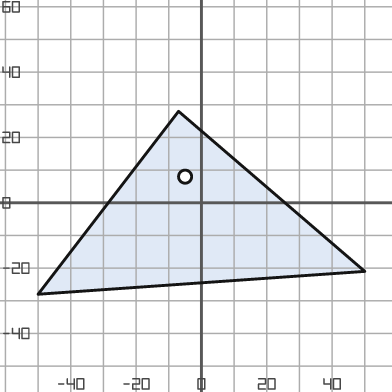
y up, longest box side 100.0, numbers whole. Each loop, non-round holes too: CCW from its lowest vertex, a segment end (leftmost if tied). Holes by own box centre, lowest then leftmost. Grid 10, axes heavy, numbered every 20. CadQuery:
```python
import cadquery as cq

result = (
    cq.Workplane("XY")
    .moveTo(-50.0, -28.0)
    .lineTo(50.0, -21.0)
    .lineTo(-7.0, 28.0)
    .close()
    .moveTo(-5.0, 8.0)
    .circle(2.0)
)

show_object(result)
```